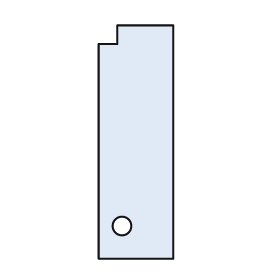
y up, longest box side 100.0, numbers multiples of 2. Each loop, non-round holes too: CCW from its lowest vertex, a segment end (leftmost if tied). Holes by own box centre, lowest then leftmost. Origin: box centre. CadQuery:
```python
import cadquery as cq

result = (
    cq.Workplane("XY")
    .moveTo(-16.0, -50.0)
    .lineTo(16.0, -50.0)
    .lineTo(16.0, 50.0)
    .lineTo(-8.0, 50.0)
    .lineTo(-8.0, 42.0)
    .lineTo(-16.0, 42.0)
    .close()
    .moveTo(-6.0, -36.0)
    .circle(4.0)
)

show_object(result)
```